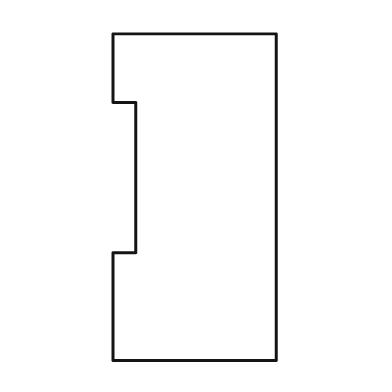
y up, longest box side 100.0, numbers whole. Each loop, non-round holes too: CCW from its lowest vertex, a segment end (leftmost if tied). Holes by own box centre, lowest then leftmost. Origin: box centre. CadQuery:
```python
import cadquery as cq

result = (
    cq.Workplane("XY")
    .moveTo(-25.0, -50.0)
    .lineTo(25.0, -50.0)
    .lineTo(25.0, 50.0)
    .lineTo(-25.0, 50.0)
    .lineTo(-25.0, 29.0)
    .lineTo(-18.0, 29.0)
    .lineTo(-18.0, -17.0)
    .lineTo(-25.0, -17.0)
    .close()
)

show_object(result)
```